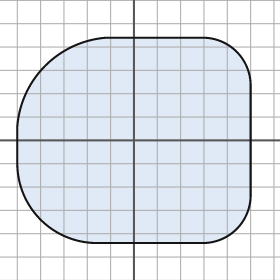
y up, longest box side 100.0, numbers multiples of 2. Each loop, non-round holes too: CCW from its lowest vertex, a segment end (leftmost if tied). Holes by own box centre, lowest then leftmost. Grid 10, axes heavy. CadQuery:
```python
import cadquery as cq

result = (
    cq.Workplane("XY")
    .moveTo(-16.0, -44.0)
    .lineTo(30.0, -44.0)
    .threePointArc((44.0, -38.0), (50.0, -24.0))
    .lineTo(50.0, 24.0)
    .threePointArc((44.0, 38.0), (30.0, 44.0))
    .lineTo(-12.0, 44.0)
    .threePointArc((-38.0, 32.0), (-50.0, 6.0))
    .lineTo(-50.0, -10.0)
    .threePointArc((-40.0, -34.0), (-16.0, -44.0))
    .close()
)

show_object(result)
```